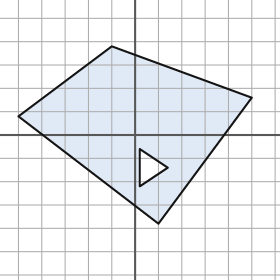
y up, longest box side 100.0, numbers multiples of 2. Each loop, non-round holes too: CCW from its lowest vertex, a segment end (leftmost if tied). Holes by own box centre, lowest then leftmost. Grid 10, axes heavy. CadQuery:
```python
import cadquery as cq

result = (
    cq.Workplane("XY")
    .moveTo(10.0, -38.0)
    .lineTo(50.0, 16.0)
    .lineTo(-10.0, 38.0)
    .lineTo(-50.0, 8.0)
    .close()
    .moveTo(2.0, -22.0)
    .lineTo(14.0, -14.0)
    .lineTo(2.0, -6.0)
    .close()
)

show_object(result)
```